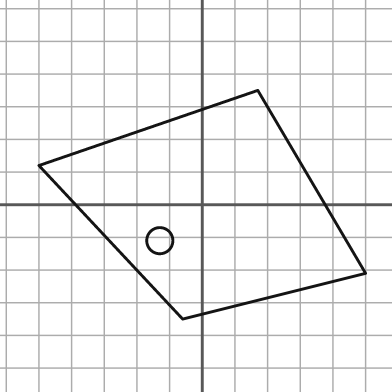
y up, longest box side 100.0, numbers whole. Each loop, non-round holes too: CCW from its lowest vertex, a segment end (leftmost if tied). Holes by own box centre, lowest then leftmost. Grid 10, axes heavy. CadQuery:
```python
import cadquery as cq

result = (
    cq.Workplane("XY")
    .moveTo(-6.0, -35.0)
    .lineTo(50.0, -21.0)
    .lineTo(17.0, 35.0)
    .lineTo(-50.0, 12.0)
    .close()
    .moveTo(-13.0, -11.0)
    .circle(4.0)
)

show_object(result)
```